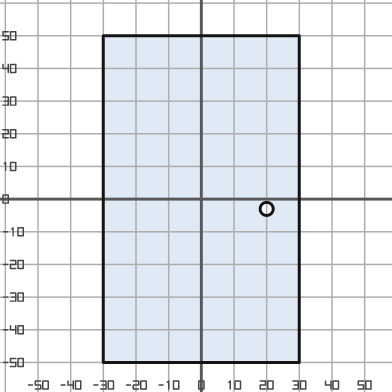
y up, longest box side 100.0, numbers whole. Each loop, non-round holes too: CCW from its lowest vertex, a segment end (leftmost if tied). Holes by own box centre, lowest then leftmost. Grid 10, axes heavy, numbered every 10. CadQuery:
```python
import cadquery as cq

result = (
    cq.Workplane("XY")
    .moveTo(-30.0, -50.0)
    .lineTo(30.0, -50.0)
    .lineTo(30.0, 50.0)
    .lineTo(-30.0, 50.0)
    .close()
    .moveTo(20.0, -3.0)
    .circle(2.0)
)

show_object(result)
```